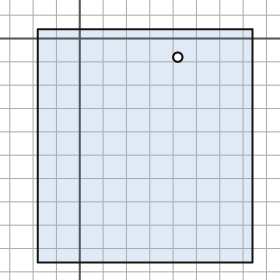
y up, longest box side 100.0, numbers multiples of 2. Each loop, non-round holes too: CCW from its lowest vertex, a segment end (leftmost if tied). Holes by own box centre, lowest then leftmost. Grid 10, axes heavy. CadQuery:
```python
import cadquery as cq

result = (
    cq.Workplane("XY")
    .moveTo(-18.0, -96.0)
    .lineTo(74.0, -96.0)
    .lineTo(74.0, 4.0)
    .lineTo(-18.0, 4.0)
    .close()
    .moveTo(42.0, -8.0)
    .circle(2.0)
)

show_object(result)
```